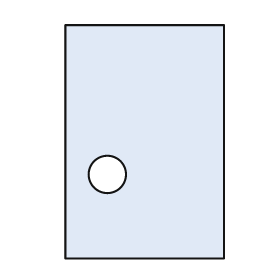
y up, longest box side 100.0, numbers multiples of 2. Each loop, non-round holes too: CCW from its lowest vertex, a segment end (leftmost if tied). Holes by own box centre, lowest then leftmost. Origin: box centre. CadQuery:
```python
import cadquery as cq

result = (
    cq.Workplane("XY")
    .moveTo(-34.0, -50.0)
    .lineTo(34.0, -50.0)
    .lineTo(34.0, 50.0)
    .lineTo(-34.0, 50.0)
    .close()
    .moveTo(-16.0, -14.0)
    .circle(8.0)
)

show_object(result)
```